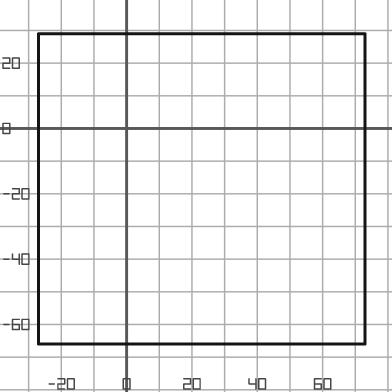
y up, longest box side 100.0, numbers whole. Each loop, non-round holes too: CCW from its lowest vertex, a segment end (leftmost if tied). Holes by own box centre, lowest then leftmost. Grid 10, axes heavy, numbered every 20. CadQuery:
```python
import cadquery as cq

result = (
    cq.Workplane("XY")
    .moveTo(-27.0, -66.0)
    .lineTo(73.0, -66.0)
    .lineTo(73.0, 29.0)
    .lineTo(-27.0, 29.0)
    .close()
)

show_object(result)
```